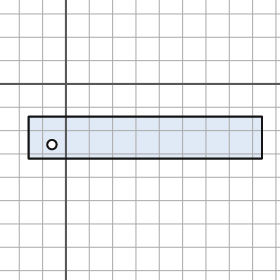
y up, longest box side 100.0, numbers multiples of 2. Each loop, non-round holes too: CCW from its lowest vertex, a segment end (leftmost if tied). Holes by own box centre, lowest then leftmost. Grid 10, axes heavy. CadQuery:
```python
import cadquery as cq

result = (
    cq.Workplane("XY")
    .moveTo(-16.0, -32.0)
    .lineTo(84.0, -32.0)
    .lineTo(84.0, -14.0)
    .lineTo(-16.0, -14.0)
    .close()
    .moveTo(-6.0, -26.0)
    .circle(2.0)
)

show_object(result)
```